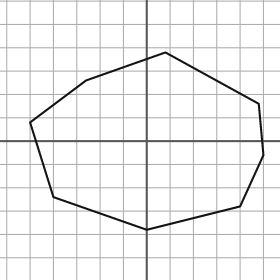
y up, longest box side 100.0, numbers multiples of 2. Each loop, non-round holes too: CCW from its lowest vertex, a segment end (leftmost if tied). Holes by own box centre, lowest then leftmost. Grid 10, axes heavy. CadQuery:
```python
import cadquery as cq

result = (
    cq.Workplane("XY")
    .moveTo(0.0, -38.0)
    .lineTo(40.0, -28.0)
    .lineTo(50.0, -6.0)
    .lineTo(48.0, 16.0)
    .lineTo(8.0, 38.0)
    .lineTo(-26.0, 26.0)
    .lineTo(-50.0, 8.0)
    .lineTo(-40.0, -24.0)
    .close()
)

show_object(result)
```